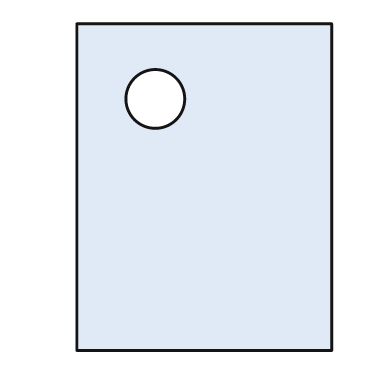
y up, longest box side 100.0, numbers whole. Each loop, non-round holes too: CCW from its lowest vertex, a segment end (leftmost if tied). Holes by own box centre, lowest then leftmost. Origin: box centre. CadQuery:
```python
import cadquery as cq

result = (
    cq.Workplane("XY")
    .moveTo(-39.0, -50.0)
    .lineTo(39.0, -50.0)
    .lineTo(39.0, 50.0)
    .lineTo(-39.0, 50.0)
    .close()
    .moveTo(-15.0, 27.0)
    .circle(9.0)
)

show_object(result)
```